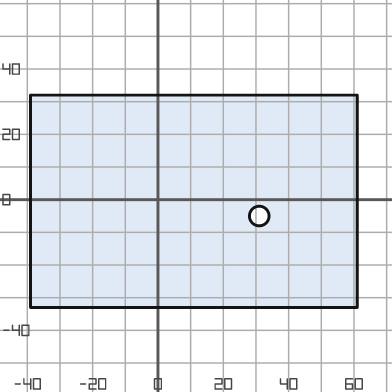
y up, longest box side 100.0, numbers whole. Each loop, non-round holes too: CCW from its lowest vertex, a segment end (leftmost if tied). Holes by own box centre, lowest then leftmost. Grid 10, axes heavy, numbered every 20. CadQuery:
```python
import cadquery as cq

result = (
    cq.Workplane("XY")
    .moveTo(-39.0, -33.0)
    .lineTo(61.0, -33.0)
    .lineTo(61.0, 32.0)
    .lineTo(-39.0, 32.0)
    .close()
    .moveTo(31.0, -5.0)
    .circle(3.0)
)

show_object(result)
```